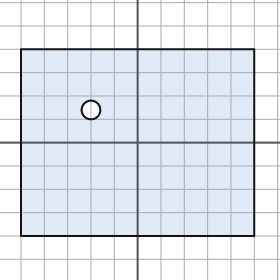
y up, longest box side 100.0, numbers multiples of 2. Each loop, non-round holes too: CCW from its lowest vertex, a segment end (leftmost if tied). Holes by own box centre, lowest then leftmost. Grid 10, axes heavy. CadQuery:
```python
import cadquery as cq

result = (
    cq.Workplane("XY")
    .moveTo(-50.0, -40.0)
    .lineTo(50.0, -40.0)
    .lineTo(50.0, 40.0)
    .lineTo(-50.0, 40.0)
    .close()
    .moveTo(-20.0, 14.0)
    .circle(4.0)
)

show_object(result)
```